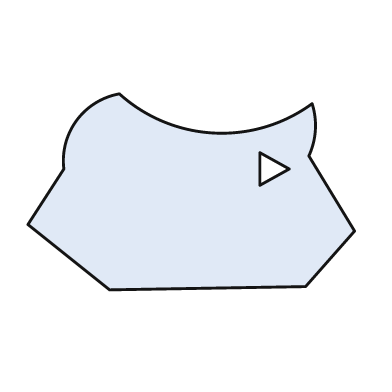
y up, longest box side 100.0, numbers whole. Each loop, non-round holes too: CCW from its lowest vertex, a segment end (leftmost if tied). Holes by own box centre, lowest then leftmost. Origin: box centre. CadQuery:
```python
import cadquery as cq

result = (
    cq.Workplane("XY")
    .moveTo(-25.0, -30.0)
    .lineTo(35.0, -29.0)
    .lineTo(50.0, -12.0)
    .lineTo(36.0, 11.0)
    .threePointArc((38.0, 19.0), (37.0, 27.0))
    .threePointArc((7.0, 18.0), (-22.0, 30.0))
    .threePointArc((-35.0, 22.0), (-39.0, 7.0))
    .lineTo(-50.0, -10.0)
    .close()
    .moveTo(21.0, 2.0)
    .lineTo(30.0, 7.0)
    .lineTo(21.0, 12.0)
    .close()
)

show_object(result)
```